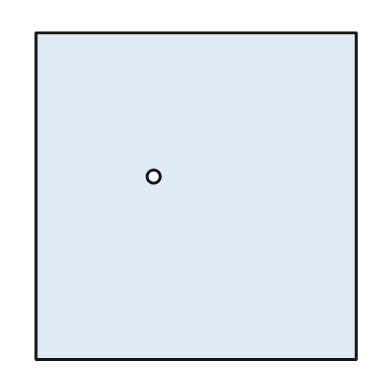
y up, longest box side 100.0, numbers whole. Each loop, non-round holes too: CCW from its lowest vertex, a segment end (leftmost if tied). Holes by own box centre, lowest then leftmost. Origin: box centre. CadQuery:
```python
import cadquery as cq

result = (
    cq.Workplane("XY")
    .moveTo(-49.0, -50.0)
    .lineTo(49.0, -50.0)
    .lineTo(49.0, 50.0)
    .lineTo(-49.0, 50.0)
    .close()
    .moveTo(-13.0, 6.0)
    .circle(2.0)
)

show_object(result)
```